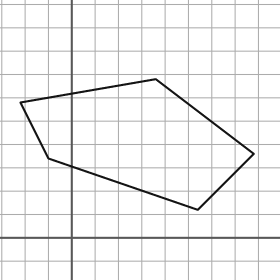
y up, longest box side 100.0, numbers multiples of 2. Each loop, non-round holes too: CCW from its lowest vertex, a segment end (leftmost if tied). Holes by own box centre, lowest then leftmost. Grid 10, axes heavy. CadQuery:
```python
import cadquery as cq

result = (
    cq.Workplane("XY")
    .moveTo(54.0, 12.0)
    .lineTo(78.0, 36.0)
    .lineTo(36.0, 68.0)
    .lineTo(-22.0, 58.0)
    .lineTo(-10.0, 34.0)
    .close()
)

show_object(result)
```